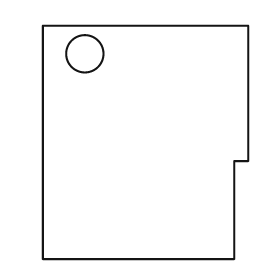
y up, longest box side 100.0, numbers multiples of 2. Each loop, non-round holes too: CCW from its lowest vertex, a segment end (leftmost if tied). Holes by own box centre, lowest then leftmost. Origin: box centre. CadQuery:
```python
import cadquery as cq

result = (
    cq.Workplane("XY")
    .moveTo(-44.0, -50.0)
    .lineTo(38.0, -50.0)
    .lineTo(38.0, -8.0)
    .lineTo(44.0, -8.0)
    .lineTo(44.0, 50.0)
    .lineTo(-44.0, 50.0)
    .close()
    .moveTo(-26.0, 38.0)
    .circle(8.0)
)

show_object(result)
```